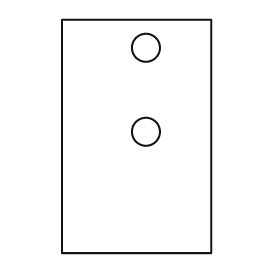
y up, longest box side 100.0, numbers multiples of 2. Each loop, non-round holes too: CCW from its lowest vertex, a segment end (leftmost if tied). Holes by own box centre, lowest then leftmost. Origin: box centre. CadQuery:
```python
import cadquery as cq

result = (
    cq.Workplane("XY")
    .moveTo(-32.0, -50.0)
    .lineTo(32.0, -50.0)
    .lineTo(32.0, 50.0)
    .lineTo(-32.0, 50.0)
    .close()
    .moveTo(4.0, 2.0)
    .circle(6.0)
    .moveTo(4.0, 38.0)
    .circle(6.0)
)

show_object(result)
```